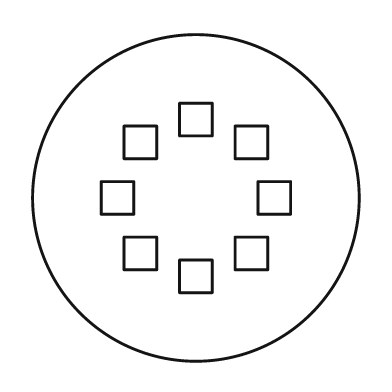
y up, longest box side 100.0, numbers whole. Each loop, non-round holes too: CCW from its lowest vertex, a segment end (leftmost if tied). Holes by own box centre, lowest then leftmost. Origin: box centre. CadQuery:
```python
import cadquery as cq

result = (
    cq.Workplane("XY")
    .moveTo(0.0, 0.0)
    .circle(50.0)
    .moveTo(-5.0, -29.0)
    .lineTo(5.0, -29.0)
    .lineTo(5.0, -19.0)
    .lineTo(-5.0, -19.0)
    .close()
    .moveTo(-22.0, -22.0)
    .lineTo(-12.0, -22.0)
    .lineTo(-12.0, -12.0)
    .lineTo(-22.0, -12.0)
    .close()
    .moveTo(12.0, -22.0)
    .lineTo(22.0, -22.0)
    .lineTo(22.0, -12.0)
    .lineTo(12.0, -12.0)
    .close()
    .moveTo(-29.0, -5.0)
    .lineTo(-19.0, -5.0)
    .lineTo(-19.0, 5.0)
    .lineTo(-29.0, 5.0)
    .close()
    .moveTo(19.0, -5.0)
    .lineTo(29.0, -5.0)
    .lineTo(29.0, 5.0)
    .lineTo(19.0, 5.0)
    .close()
    .moveTo(-22.0, 12.0)
    .lineTo(-12.0, 12.0)
    .lineTo(-12.0, 22.0)
    .lineTo(-22.0, 22.0)
    .close()
    .moveTo(12.0, 12.0)
    .lineTo(22.0, 12.0)
    .lineTo(22.0, 22.0)
    .lineTo(12.0, 22.0)
    .close()
    .moveTo(-5.0, 19.0)
    .lineTo(5.0, 19.0)
    .lineTo(5.0, 29.0)
    .lineTo(-5.0, 29.0)
    .close()
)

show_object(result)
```